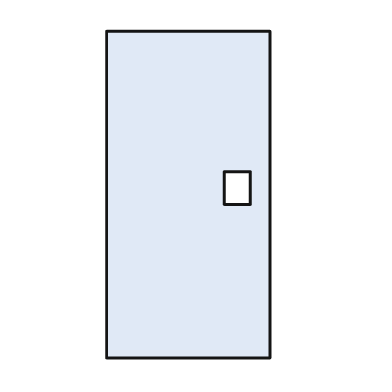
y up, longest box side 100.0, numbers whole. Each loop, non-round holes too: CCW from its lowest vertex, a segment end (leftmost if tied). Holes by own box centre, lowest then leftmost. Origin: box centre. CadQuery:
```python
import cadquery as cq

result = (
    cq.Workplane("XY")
    .moveTo(-25.0, -50.0)
    .lineTo(25.0, -50.0)
    .lineTo(25.0, 50.0)
    .lineTo(-25.0, 50.0)
    .close()
    .moveTo(11.0, -3.0)
    .lineTo(19.0, -3.0)
    .lineTo(19.0, 7.0)
    .lineTo(11.0, 7.0)
    .close()
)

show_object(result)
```